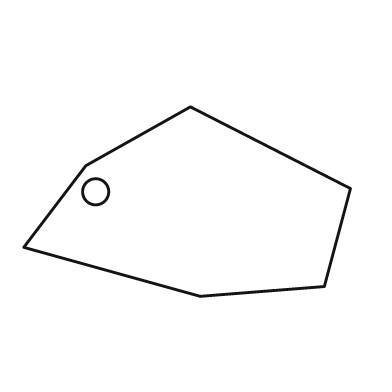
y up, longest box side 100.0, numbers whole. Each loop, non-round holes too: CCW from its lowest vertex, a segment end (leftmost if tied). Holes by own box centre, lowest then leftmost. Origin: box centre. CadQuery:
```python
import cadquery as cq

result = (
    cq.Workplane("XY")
    .moveTo(4.0, -29.0)
    .lineTo(42.0, -26.0)
    .lineTo(50.0, 4.0)
    .lineTo(1.0, 29.0)
    .lineTo(-31.0, 11.0)
    .lineTo(-50.0, -14.0)
    .close()
    .moveTo(-28.0, 3.0)
    .circle(4.0)
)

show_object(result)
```